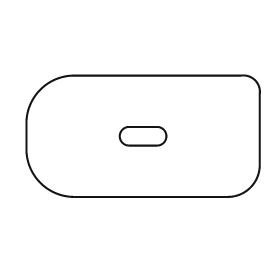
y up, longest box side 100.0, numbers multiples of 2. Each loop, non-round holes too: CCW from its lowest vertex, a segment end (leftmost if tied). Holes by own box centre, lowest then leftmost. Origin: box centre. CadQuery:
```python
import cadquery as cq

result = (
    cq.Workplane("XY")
    .moveTo(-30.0, -26.0)
    .lineTo(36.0, -26.0)
    .threePointArc((46.0, -22.0), (50.0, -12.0))
    .lineTo(50.0, 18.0)
    .threePointArc((48.0, 24.0), (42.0, 26.0))
    .lineTo(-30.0, 26.0)
    .threePointArc((-44.0, 20.0), (-50.0, 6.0))
    .lineTo(-50.0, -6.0)
    .threePointArc((-44.0, -20.0), (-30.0, -26.0))
    .close()
    .moveTo(-6.0, -4.0)
    .lineTo(6.0, -4.0)
    .threePointArc((10.0, 0.0), (6.0, 4.0))
    .lineTo(-6.0, 4.0)
    .threePointArc((-10.0, 0.0), (-6.0, -4.0))
    .close()
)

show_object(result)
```